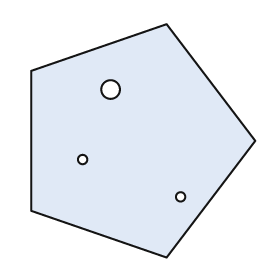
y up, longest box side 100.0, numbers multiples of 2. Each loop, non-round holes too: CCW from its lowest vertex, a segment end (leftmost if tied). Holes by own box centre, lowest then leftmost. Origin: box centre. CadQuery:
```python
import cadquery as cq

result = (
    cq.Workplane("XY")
    .moveTo(10.0, -50.0)
    .lineTo(48.0, 0.0)
    .lineTo(10.0, 50.0)
    .lineTo(-48.0, 30.0)
    .lineTo(-48.0, -30.0)
    .close()
    .moveTo(16.0, -24.0)
    .circle(2.0)
    .moveTo(-26.0, -8.0)
    .circle(2.0)
    .moveTo(-14.0, 22.0)
    .circle(4.0)
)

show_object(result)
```